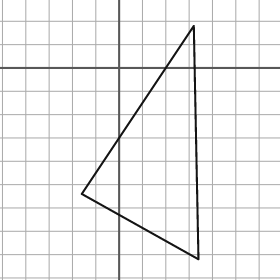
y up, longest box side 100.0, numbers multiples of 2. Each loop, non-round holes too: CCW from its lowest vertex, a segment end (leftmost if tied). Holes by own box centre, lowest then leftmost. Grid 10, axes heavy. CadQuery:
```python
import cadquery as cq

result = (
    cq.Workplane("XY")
    .moveTo(34.0, -82.0)
    .lineTo(32.0, 18.0)
    .lineTo(-16.0, -54.0)
    .close()
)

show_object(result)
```